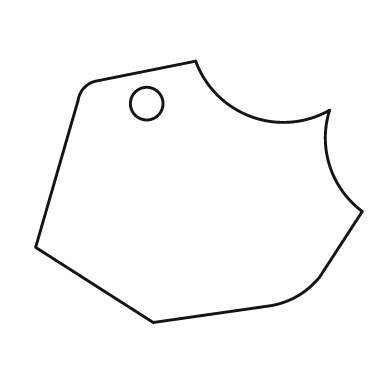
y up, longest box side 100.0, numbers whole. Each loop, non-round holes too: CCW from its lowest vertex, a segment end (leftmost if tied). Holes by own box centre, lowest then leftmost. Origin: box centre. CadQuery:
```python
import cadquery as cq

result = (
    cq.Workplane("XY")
    .moveTo(-14.0, -40.0)
    .lineTo(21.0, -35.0)
    .threePointArc((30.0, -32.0), (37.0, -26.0))
    .lineTo(50.0, -6.0)
    .threePointArc((40.0, 8.0), (40.0, 25.0))
    .threePointArc((16.0, 23.0), (-1.0, 40.0))
    .lineTo(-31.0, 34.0)
    .threePointArc((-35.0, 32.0), (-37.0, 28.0))
    .lineTo(-50.0, -17.0)
    .close()
    .moveTo(-16.0, 27.0)
    .circle(5.0)
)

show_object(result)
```